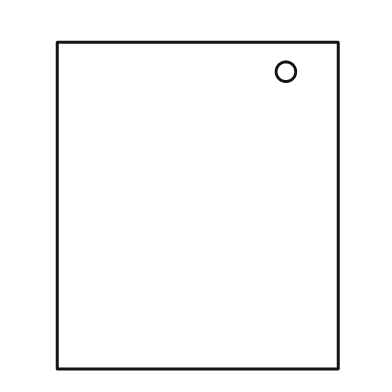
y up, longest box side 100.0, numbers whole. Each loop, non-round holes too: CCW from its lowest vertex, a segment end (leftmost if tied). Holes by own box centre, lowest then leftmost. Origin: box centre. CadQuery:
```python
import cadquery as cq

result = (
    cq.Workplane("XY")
    .moveTo(-43.0, -50.0)
    .lineTo(43.0, -50.0)
    .lineTo(43.0, 50.0)
    .lineTo(-43.0, 50.0)
    .close()
    .moveTo(27.0, 41.0)
    .circle(3.0)
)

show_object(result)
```